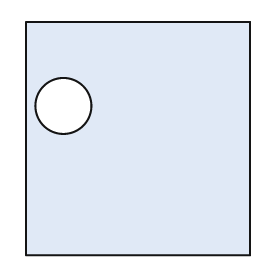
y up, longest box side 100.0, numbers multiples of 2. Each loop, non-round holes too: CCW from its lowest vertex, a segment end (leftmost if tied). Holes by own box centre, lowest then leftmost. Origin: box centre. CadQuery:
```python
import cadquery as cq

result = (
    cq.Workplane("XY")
    .moveTo(-48.0, -50.0)
    .lineTo(48.0, -50.0)
    .lineTo(48.0, 50.0)
    .lineTo(-48.0, 50.0)
    .close()
    .moveTo(-32.0, 14.0)
    .circle(12.0)
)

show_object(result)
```